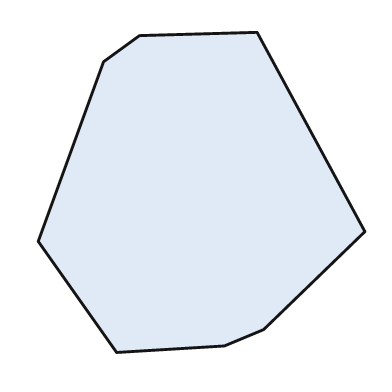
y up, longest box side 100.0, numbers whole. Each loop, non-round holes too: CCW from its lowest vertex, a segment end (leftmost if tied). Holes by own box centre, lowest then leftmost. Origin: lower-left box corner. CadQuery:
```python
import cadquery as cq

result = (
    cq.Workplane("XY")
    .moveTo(24.0, 0.0)
    .lineTo(57.0, 2.0)
    .lineTo(69.0, 7.0)
    .lineTo(100.0, 37.0)
    .lineTo(67.0, 98.0)
    .lineTo(31.0, 97.0)
    .lineTo(20.0, 89.0)
    .lineTo(0.0, 34.0)
    .close()
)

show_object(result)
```